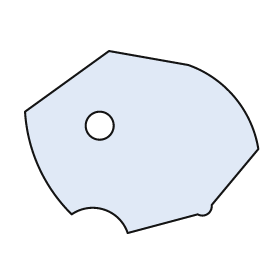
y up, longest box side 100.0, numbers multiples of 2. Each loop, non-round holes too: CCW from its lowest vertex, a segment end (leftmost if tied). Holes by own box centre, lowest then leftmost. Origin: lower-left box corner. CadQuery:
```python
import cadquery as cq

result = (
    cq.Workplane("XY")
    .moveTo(44.0, 0.0)
    .lineTo(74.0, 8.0)
    .threePointArc((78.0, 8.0), (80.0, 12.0))
    .lineTo(100.0, 36.0)
    .threePointArc((90.0, 58.0), (70.0, 72.0))
    .lineTo(36.0, 78.0)
    .lineTo(0.0, 52.0)
    .threePointArc((6.0, 28.0), (20.0, 8.0))
    .threePointArc((34.0, 10.0), (44.0, 0.0))
    .close()
    .moveTo(32.0, 46.0)
    .circle(6.0)
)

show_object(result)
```